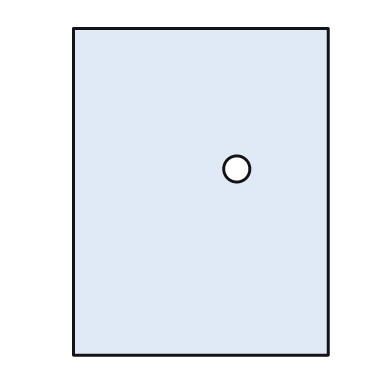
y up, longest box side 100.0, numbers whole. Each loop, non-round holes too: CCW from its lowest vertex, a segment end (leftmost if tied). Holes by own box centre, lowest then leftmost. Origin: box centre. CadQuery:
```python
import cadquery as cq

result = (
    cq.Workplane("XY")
    .moveTo(-39.0, -50.0)
    .lineTo(39.0, -50.0)
    .lineTo(39.0, 50.0)
    .lineTo(-39.0, 50.0)
    .close()
    .moveTo(11.0, 7.0)
    .circle(4.0)
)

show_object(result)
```